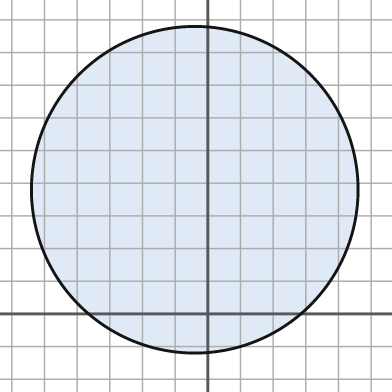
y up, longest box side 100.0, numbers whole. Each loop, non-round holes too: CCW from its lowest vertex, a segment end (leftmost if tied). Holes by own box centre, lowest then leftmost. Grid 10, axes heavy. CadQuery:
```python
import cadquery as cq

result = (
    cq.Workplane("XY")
    .moveTo(-4.0, 38.0)
    .circle(50.0)
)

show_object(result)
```